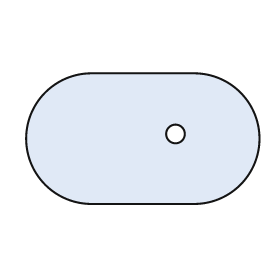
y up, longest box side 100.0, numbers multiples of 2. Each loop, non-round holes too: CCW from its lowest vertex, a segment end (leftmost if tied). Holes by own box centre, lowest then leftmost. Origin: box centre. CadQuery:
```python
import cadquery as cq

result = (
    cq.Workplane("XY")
    .moveTo(-22.0, -28.0)
    .lineTo(22.0, -28.0)
    .threePointArc((50.0, 0.0), (22.0, 28.0))
    .lineTo(-22.0, 28.0)
    .threePointArc((-50.0, 0.0), (-22.0, -28.0))
    .close()
    .moveTo(14.0, 2.0)
    .circle(4.0)
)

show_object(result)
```